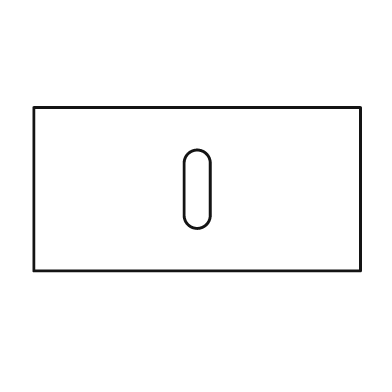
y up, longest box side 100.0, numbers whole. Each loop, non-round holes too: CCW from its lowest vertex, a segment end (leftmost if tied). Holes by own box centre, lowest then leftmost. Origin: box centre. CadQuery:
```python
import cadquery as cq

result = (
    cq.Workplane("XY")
    .moveTo(-50.0, -25.0)
    .lineTo(50.0, -25.0)
    .lineTo(50.0, 25.0)
    .lineTo(-50.0, 25.0)
    .close()
    .moveTo(-4.0, -8.0)
    .threePointArc((0.0, -12.0), (4.0, -8.0))
    .lineTo(4.0, 8.0)
    .threePointArc((0.0, 12.0), (-4.0, 8.0))
    .close()
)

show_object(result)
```